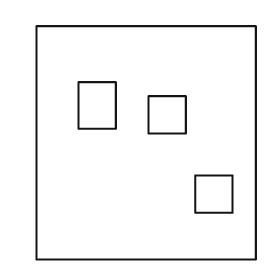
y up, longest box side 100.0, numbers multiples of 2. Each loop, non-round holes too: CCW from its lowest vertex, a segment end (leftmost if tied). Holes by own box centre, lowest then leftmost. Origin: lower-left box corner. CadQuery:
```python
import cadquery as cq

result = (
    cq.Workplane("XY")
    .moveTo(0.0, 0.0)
    .lineTo(94.0, 0.0)
    .lineTo(94.0, 100.0)
    .lineTo(0.0, 100.0)
    .close()
    .moveTo(68.0, 20.0)
    .lineTo(84.0, 20.0)
    .lineTo(84.0, 36.0)
    .lineTo(68.0, 36.0)
    .close()
    .moveTo(48.0, 54.0)
    .lineTo(64.0, 54.0)
    .lineTo(64.0, 70.0)
    .lineTo(48.0, 70.0)
    .close()
    .moveTo(18.0, 56.0)
    .lineTo(34.0, 56.0)
    .lineTo(34.0, 76.0)
    .lineTo(18.0, 76.0)
    .close()
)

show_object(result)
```